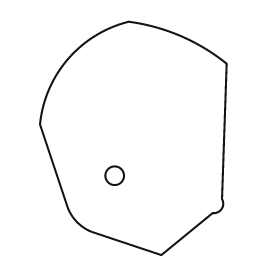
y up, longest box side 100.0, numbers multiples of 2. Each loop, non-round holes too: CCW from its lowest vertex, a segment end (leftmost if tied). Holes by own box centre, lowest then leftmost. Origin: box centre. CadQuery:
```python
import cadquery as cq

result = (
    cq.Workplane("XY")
    .moveTo(12.0, -50.0)
    .lineTo(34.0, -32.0)
    .threePointArc((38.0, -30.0), (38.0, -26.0))
    .lineTo(40.0, 32.0)
    .threePointArc((20.0, 44.0), (-2.0, 50.0))
    .threePointArc((-28.0, 34.0), (-40.0, 6.0))
    .lineTo(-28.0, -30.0)
    .threePointArc((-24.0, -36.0), (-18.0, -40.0))
    .close()
    .moveTo(-8.0, -16.0)
    .circle(4.0)
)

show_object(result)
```